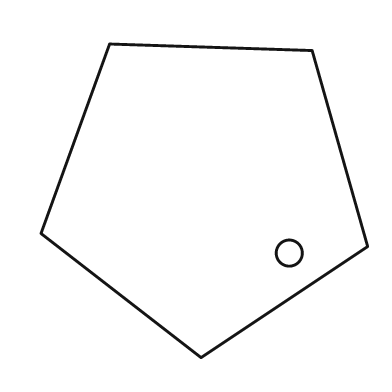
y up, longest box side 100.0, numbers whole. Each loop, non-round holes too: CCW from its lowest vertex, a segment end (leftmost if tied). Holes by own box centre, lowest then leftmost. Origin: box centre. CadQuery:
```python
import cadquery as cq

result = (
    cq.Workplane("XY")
    .moveTo(-1.0, -48.0)
    .lineTo(50.0, -14.0)
    .lineTo(33.0, 46.0)
    .lineTo(-29.0, 48.0)
    .lineTo(-50.0, -10.0)
    .close()
    .moveTo(26.0, -16.0)
    .circle(4.0)
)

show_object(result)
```